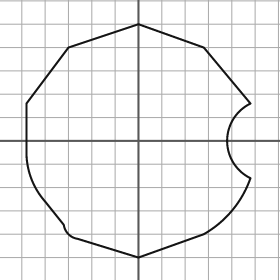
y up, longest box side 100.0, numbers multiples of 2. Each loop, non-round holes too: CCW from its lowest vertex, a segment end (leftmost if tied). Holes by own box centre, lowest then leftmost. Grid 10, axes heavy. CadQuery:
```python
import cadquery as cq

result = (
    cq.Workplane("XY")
    .moveTo(0.0, -50.0)
    .lineTo(28.0, -40.0)
    .threePointArc((40.0, -30.0), (48.0, -16.0))
    .threePointArc((38.0, 0.0), (48.0, 16.0))
    .lineTo(28.0, 40.0)
    .lineTo(0.0, 50.0)
    .lineTo(-30.0, 40.0)
    .lineTo(-48.0, 16.0)
    .lineTo(-48.0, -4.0)
    .threePointArc((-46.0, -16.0), (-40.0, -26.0))
    .lineTo(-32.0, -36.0)
    .threePointArc((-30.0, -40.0), (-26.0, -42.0))
    .close()
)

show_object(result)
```